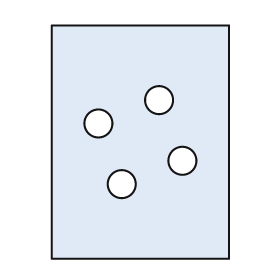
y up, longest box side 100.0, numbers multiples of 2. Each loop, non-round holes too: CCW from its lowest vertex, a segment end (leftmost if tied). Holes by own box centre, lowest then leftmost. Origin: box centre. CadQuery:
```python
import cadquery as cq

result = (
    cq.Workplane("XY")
    .moveTo(-38.0, -50.0)
    .lineTo(38.0, -50.0)
    .lineTo(38.0, 50.0)
    .lineTo(-38.0, 50.0)
    .close()
    .moveTo(-8.0, -18.0)
    .circle(6.0)
    .moveTo(18.0, -8.0)
    .circle(6.0)
    .moveTo(-18.0, 8.0)
    .circle(6.0)
    .moveTo(8.0, 18.0)
    .circle(6.0)
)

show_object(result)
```